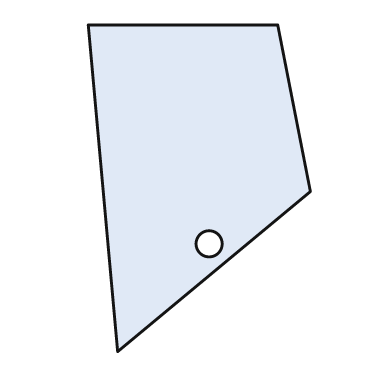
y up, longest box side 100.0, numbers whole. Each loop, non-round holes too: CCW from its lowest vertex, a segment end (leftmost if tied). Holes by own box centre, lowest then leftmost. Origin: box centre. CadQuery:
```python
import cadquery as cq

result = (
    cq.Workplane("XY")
    .moveTo(-25.0, -50.0)
    .lineTo(34.0, -1.0)
    .lineTo(24.0, 50.0)
    .lineTo(-34.0, 50.0)
    .close()
    .moveTo(3.0, -17.0)
    .circle(4.0)
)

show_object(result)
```